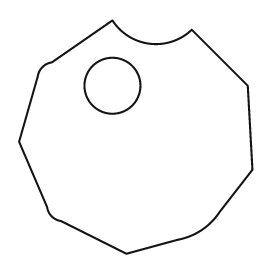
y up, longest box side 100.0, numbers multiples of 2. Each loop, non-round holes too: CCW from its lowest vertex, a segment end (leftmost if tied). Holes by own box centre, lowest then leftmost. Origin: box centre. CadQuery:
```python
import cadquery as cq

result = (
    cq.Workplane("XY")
    .moveTo(-4.0, -50.0)
    .lineTo(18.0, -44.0)
    .threePointArc((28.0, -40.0), (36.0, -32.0))
    .lineTo(50.0, -14.0)
    .lineTo(48.0, 22.0)
    .lineTo(24.0, 46.0)
    .threePointArc((6.0, 40.0), (-10.0, 50.0))
    .lineTo(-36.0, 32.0)
    .threePointArc((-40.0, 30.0), (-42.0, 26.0))
    .lineTo(-50.0, -2.0)
    .lineTo(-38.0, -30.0)
    .threePointArc((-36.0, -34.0), (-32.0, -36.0))
    .close()
    .moveTo(-10.0, 22.0)
    .circle(12.0)
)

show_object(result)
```